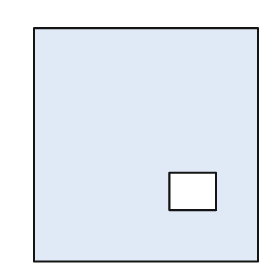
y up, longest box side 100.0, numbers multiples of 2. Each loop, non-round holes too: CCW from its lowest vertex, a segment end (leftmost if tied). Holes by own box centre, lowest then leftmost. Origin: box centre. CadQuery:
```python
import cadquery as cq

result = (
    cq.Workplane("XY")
    .moveTo(-48.0, -50.0)
    .lineTo(48.0, -50.0)
    .lineTo(48.0, 50.0)
    .lineTo(-48.0, 50.0)
    .close()
    .moveTo(10.0, -28.0)
    .lineTo(30.0, -28.0)
    .lineTo(30.0, -12.0)
    .lineTo(10.0, -12.0)
    .close()
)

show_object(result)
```